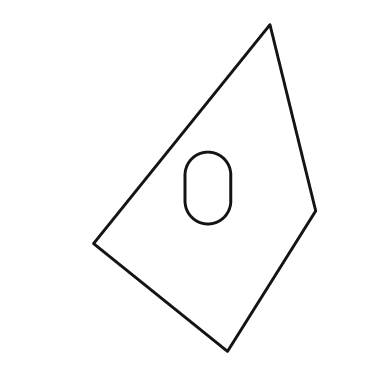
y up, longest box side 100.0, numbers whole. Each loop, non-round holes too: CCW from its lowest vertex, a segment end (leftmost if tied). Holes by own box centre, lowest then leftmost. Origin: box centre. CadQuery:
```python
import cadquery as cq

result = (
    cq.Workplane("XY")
    .moveTo(7.0, -50.0)
    .lineTo(34.0, -7.0)
    .lineTo(20.0, 50.0)
    .lineTo(-34.0, -17.0)
    .close()
    .moveTo(-6.0, -4.0)
    .threePointArc((1.0, -11.0), (8.0, -4.0))
    .lineTo(8.0, 4.0)
    .threePointArc((1.0, 11.0), (-6.0, 4.0))
    .close()
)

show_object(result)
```